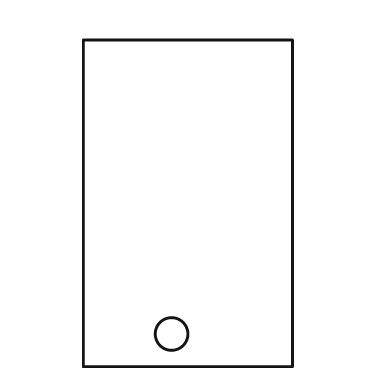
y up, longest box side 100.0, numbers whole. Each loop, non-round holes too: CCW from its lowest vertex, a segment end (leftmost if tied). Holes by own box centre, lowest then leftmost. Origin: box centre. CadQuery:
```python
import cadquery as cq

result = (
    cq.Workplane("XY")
    .moveTo(-32.0, -50.0)
    .lineTo(32.0, -50.0)
    .lineTo(32.0, 50.0)
    .lineTo(-32.0, 50.0)
    .close()
    .moveTo(-5.0, -40.0)
    .circle(5.0)
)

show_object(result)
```